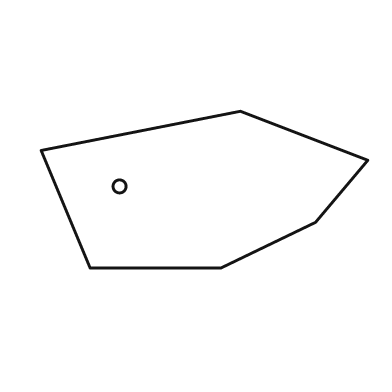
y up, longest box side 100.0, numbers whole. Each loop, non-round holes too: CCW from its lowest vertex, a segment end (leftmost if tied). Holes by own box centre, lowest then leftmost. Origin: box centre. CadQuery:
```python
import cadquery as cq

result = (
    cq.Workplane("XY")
    .moveTo(-35.0, -24.0)
    .lineTo(5.0, -24.0)
    .lineTo(34.0, -10.0)
    .lineTo(50.0, 9.0)
    .lineTo(11.0, 24.0)
    .lineTo(-50.0, 12.0)
    .close()
    .moveTo(-26.0, 1.0)
    .circle(2.0)
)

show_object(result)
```